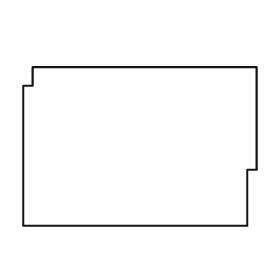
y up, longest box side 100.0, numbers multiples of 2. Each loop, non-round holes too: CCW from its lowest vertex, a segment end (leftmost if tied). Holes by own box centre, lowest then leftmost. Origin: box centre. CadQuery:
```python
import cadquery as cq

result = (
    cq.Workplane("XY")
    .moveTo(-50.0, -34.0)
    .lineTo(46.0, -34.0)
    .lineTo(46.0, -10.0)
    .lineTo(50.0, -10.0)
    .lineTo(50.0, 34.0)
    .lineTo(-46.0, 34.0)
    .lineTo(-46.0, 26.0)
    .lineTo(-50.0, 26.0)
    .close()
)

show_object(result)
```